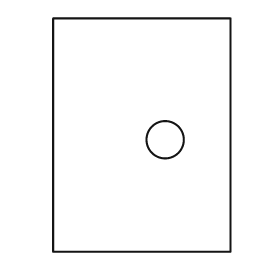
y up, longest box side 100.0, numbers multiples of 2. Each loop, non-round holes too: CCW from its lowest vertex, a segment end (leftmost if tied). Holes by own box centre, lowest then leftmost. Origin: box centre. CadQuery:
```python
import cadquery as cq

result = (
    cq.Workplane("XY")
    .moveTo(-38.0, -50.0)
    .lineTo(38.0, -50.0)
    .lineTo(38.0, 50.0)
    .lineTo(-38.0, 50.0)
    .close()
    .moveTo(10.0, -2.0)
    .circle(8.0)
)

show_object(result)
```